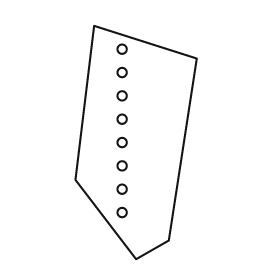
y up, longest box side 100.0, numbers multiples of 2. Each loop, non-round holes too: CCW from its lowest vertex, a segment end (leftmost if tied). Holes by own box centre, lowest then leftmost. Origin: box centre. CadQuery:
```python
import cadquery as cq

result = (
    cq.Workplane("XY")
    .moveTo(0.0, -50.0)
    .lineTo(14.0, -42.0)
    .lineTo(26.0, 36.0)
    .lineTo(-18.0, 50.0)
    .lineTo(-26.0, -16.0)
    .close()
    .moveTo(-6.0, -30.0)
    .circle(2.0)
    .moveTo(-6.0, -20.0)
    .circle(2.0)
    .moveTo(-6.0, -10.0)
    .circle(2.0)
    .moveTo(-6.0, 0.0)
    .circle(2.0)
    .moveTo(-6.0, 10.0)
    .circle(2.0)
    .moveTo(-6.0, 20.0)
    .circle(2.0)
    .moveTo(-6.0, 30.0)
    .circle(2.0)
    .moveTo(-6.0, 40.0)
    .circle(2.0)
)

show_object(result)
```